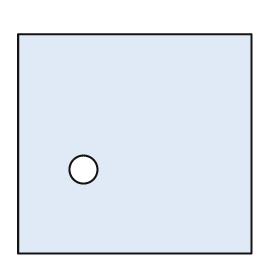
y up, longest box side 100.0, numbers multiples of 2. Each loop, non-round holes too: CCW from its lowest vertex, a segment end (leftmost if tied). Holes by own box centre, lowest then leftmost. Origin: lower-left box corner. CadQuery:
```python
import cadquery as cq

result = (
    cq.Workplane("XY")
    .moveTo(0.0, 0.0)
    .lineTo(100.0, 0.0)
    .lineTo(100.0, 94.0)
    .lineTo(0.0, 94.0)
    .close()
    .moveTo(28.0, 36.0)
    .circle(6.0)
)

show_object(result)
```